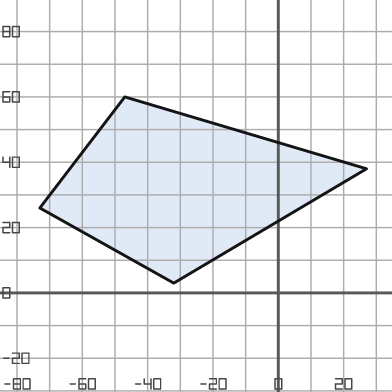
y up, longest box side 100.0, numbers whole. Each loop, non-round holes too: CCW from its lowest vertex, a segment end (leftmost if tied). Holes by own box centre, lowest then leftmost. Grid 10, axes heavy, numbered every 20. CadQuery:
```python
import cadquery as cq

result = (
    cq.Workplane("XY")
    .moveTo(-32.0, 3.0)
    .lineTo(27.0, 38.0)
    .lineTo(-47.0, 60.0)
    .lineTo(-73.0, 26.0)
    .close()
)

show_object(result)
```